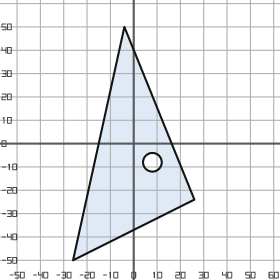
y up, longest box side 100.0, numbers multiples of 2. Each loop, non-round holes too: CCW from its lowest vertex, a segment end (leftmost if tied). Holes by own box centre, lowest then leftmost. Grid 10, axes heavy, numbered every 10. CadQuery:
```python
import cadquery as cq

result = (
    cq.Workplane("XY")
    .moveTo(-26.0, -50.0)
    .lineTo(26.0, -24.0)
    .lineTo(-4.0, 50.0)
    .close()
    .moveTo(8.0, -8.0)
    .circle(4.0)
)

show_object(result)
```